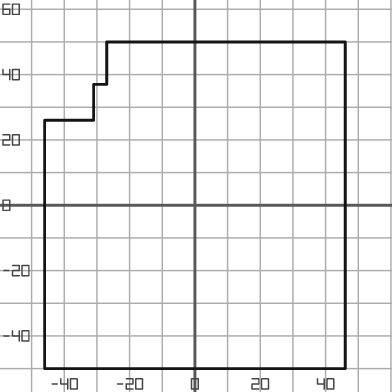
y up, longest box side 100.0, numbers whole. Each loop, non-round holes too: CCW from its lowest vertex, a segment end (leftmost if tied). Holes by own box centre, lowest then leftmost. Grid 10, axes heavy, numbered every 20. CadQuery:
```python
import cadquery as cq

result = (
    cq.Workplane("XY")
    .moveTo(-46.0, -50.0)
    .lineTo(46.0, -50.0)
    .lineTo(46.0, 50.0)
    .lineTo(-27.0, 50.0)
    .lineTo(-27.0, 37.0)
    .lineTo(-31.0, 37.0)
    .lineTo(-31.0, 26.0)
    .lineTo(-46.0, 26.0)
    .close()
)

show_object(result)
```